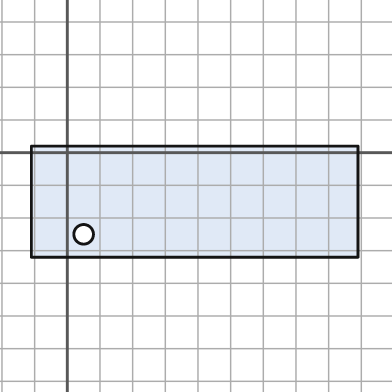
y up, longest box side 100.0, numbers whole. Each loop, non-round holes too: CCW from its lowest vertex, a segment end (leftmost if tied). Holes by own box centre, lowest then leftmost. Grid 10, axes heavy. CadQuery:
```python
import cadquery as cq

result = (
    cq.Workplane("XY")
    .moveTo(-11.0, -32.0)
    .lineTo(89.0, -32.0)
    .lineTo(89.0, 2.0)
    .lineTo(-11.0, 2.0)
    .close()
    .moveTo(5.0, -25.0)
    .circle(3.0)
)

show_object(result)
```